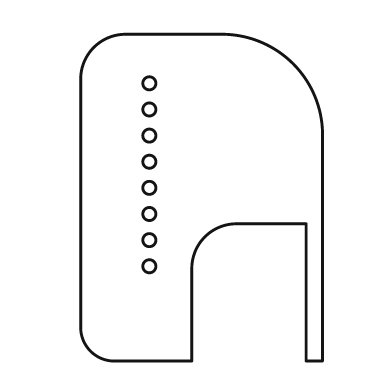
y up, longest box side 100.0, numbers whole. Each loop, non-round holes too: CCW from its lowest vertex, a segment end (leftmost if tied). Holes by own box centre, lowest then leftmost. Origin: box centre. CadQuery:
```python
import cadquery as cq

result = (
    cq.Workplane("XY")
    .moveTo(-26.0, -50.0)
    .lineTo(-3.0, -50.0)
    .lineTo(-3.0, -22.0)
    .threePointArc((1.0, -12.0), (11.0, -8.0))
    .lineTo(32.0, -8.0)
    .lineTo(32.0, -50.0)
    .lineTo(37.0, -50.0)
    .lineTo(37.0, 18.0)
    .threePointArc((28.0, 41.0), (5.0, 50.0))
    .lineTo(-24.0, 50.0)
    .threePointArc((-33.0, 46.0), (-37.0, 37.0))
    .lineTo(-37.0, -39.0)
    .threePointArc((-34.0, -47.0), (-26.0, -50.0))
    .close()
    .moveTo(-16.0, -21.0)
    .circle(2.0)
    .moveTo(-16.0, -13.0)
    .circle(2.0)
    .moveTo(-16.0, -5.0)
    .circle(2.0)
    .moveTo(-16.0, 3.0)
    .circle(2.0)
    .moveTo(-16.0, 11.0)
    .circle(2.0)
    .moveTo(-16.0, 19.0)
    .circle(2.0)
    .moveTo(-16.0, 27.0)
    .circle(2.0)
    .moveTo(-16.0, 35.0)
    .circle(2.0)
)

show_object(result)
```